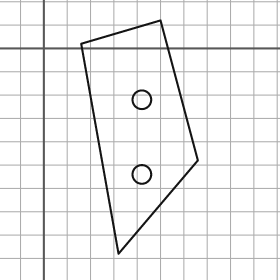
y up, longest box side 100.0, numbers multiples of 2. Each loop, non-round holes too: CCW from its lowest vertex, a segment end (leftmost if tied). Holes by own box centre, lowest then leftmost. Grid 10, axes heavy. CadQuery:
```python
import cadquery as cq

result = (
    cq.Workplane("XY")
    .moveTo(32.0, -88.0)
    .lineTo(66.0, -48.0)
    .lineTo(50.0, 12.0)
    .lineTo(16.0, 2.0)
    .close()
    .moveTo(42.0, -54.0)
    .circle(4.0)
    .moveTo(42.0, -22.0)
    .circle(4.0)
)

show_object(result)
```